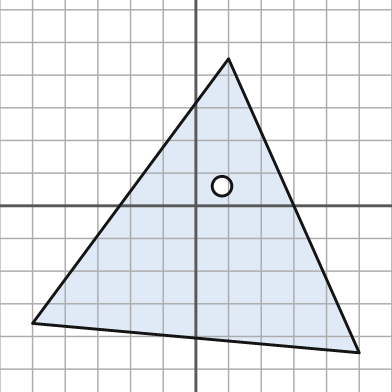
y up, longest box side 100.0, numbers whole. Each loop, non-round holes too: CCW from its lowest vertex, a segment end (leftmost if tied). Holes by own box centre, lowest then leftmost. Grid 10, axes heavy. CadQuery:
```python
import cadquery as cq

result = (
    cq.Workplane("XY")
    .moveTo(50.0, -45.0)
    .lineTo(10.0, 45.0)
    .lineTo(-50.0, -36.0)
    .close()
    .moveTo(8.0, 6.0)
    .circle(3.0)
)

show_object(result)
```